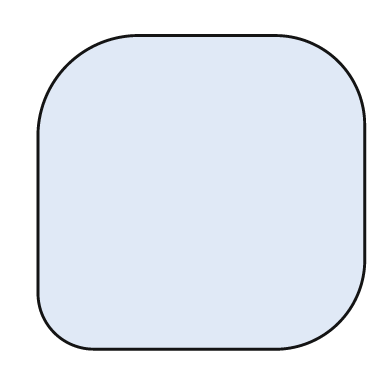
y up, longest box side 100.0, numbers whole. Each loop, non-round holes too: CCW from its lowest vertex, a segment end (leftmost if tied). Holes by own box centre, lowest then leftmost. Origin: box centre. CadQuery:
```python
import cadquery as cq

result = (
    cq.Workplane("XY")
    .moveTo(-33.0, -48.0)
    .lineTo(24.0, -48.0)
    .threePointArc((42.0, -40.0), (50.0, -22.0))
    .lineTo(50.0, 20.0)
    .threePointArc((42.0, 40.0), (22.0, 48.0))
    .lineTo(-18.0, 48.0)
    .threePointArc((-41.0, 39.0), (-50.0, 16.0))
    .lineTo(-50.0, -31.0)
    .threePointArc((-45.0, -43.0), (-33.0, -48.0))
    .close()
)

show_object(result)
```